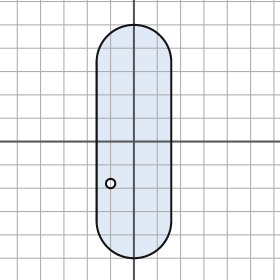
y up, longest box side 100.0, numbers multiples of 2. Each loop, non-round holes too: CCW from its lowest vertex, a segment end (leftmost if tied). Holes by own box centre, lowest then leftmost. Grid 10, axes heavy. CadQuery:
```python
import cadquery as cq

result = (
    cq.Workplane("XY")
    .moveTo(-16.0, -34.0)
    .threePointArc((0.0, -50.0), (16.0, -34.0))
    .lineTo(16.0, 34.0)
    .threePointArc((0.0, 50.0), (-16.0, 34.0))
    .close()
    .moveTo(-10.0, -18.0)
    .circle(2.0)
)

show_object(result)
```